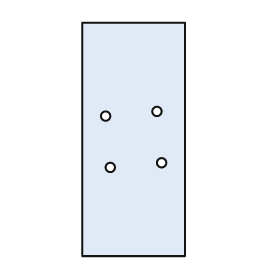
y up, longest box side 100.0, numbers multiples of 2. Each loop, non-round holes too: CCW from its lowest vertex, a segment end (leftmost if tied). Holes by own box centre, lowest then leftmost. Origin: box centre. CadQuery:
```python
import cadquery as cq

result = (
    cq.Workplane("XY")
    .moveTo(-22.0, -50.0)
    .lineTo(22.0, -50.0)
    .lineTo(22.0, 50.0)
    .lineTo(-22.0, 50.0)
    .close()
    .moveTo(-10.0, -12.0)
    .circle(2.0)
    .moveTo(12.0, -10.0)
    .circle(2.0)
    .moveTo(-12.0, 10.0)
    .circle(2.0)
    .moveTo(10.0, 12.0)
    .circle(2.0)
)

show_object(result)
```